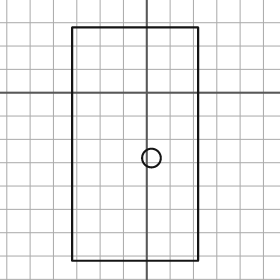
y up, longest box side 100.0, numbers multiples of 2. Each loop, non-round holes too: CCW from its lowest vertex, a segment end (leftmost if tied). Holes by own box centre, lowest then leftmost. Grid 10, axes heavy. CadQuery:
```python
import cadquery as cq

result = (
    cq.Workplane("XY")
    .moveTo(-32.0, -72.0)
    .lineTo(22.0, -72.0)
    .lineTo(22.0, 28.0)
    .lineTo(-32.0, 28.0)
    .close()
    .moveTo(2.0, -28.0)
    .circle(4.0)
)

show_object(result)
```